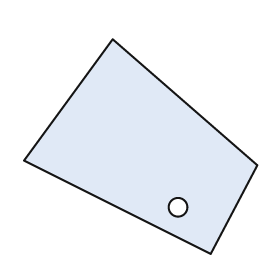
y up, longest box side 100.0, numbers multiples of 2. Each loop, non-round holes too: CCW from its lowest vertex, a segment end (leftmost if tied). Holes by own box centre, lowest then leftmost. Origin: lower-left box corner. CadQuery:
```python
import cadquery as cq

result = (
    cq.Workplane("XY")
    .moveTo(80.0, 0.0)
    .lineTo(100.0, 38.0)
    .lineTo(38.0, 92.0)
    .lineTo(0.0, 40.0)
    .close()
    .moveTo(66.0, 20.0)
    .circle(4.0)
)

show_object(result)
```